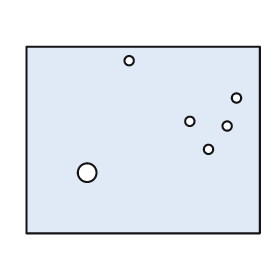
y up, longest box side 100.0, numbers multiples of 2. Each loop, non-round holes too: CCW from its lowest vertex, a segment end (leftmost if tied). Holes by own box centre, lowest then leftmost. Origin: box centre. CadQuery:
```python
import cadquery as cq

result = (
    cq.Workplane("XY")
    .moveTo(-50.0, -40.0)
    .lineTo(50.0, -40.0)
    .lineTo(50.0, 40.0)
    .lineTo(-50.0, 40.0)
    .close()
    .moveTo(-24.0, -14.0)
    .circle(4.0)
    .moveTo(28.0, -4.0)
    .circle(2.0)
    .moveTo(36.0, 6.0)
    .circle(2.0)
    .moveTo(20.0, 8.0)
    .circle(2.0)
    .moveTo(40.0, 18.0)
    .circle(2.0)
    .moveTo(-6.0, 34.0)
    .circle(2.0)
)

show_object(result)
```